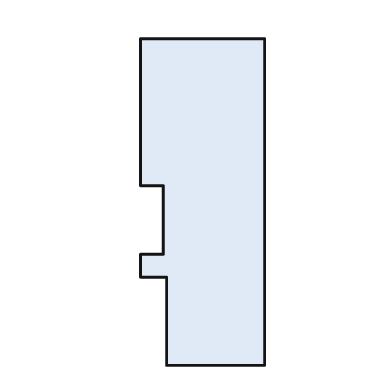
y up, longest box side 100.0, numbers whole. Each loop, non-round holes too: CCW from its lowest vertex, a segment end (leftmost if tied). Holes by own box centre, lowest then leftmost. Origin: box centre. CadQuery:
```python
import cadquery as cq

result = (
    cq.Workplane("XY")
    .moveTo(-11.0, -50.0)
    .lineTo(19.0, -50.0)
    .lineTo(19.0, 50.0)
    .lineTo(-19.0, 50.0)
    .lineTo(-19.0, 5.0)
    .lineTo(-12.0, 5.0)
    .lineTo(-12.0, -16.0)
    .lineTo(-19.0, -16.0)
    .lineTo(-19.0, -23.0)
    .lineTo(-11.0, -23.0)
    .close()
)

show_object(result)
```